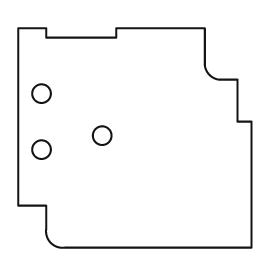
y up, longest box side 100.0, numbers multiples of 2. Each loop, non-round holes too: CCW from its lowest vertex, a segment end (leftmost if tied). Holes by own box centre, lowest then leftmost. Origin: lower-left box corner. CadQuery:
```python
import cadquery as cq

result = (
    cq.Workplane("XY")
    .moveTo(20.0, 0.0)
    .lineTo(100.0, 0.0)
    .lineTo(100.0, 54.0)
    .lineTo(94.0, 54.0)
    .lineTo(94.0, 72.0)
    .lineTo(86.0, 72.0)
    .threePointArc((82.0, 74.0), (80.0, 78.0))
    .lineTo(80.0, 94.0)
    .lineTo(42.0, 94.0)
    .lineTo(42.0, 90.0)
    .lineTo(12.0, 90.0)
    .lineTo(12.0, 94.0)
    .lineTo(0.0, 94.0)
    .lineTo(0.0, 18.0)
    .lineTo(12.0, 18.0)
    .lineTo(12.0, 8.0)
    .threePointArc((14.0, 2.0), (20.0, 0.0))
    .close()
    .moveTo(10.0, 42.0)
    .circle(4.0)
    .moveTo(36.0, 48.0)
    .circle(4.0)
    .moveTo(10.0, 66.0)
    .circle(4.0)
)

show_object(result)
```